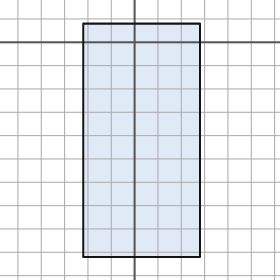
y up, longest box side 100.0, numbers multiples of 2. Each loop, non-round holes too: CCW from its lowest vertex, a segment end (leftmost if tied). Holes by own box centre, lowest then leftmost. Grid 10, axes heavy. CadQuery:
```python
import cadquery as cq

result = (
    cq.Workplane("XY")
    .moveTo(-22.0, -92.0)
    .lineTo(28.0, -92.0)
    .lineTo(28.0, 8.0)
    .lineTo(-22.0, 8.0)
    .close()
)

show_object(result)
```